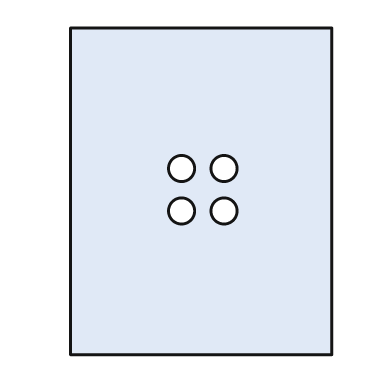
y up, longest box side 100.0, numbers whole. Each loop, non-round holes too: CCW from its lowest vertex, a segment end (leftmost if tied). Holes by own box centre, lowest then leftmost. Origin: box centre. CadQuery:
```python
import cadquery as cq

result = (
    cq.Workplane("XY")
    .moveTo(-40.0, -50.0)
    .lineTo(40.0, -50.0)
    .lineTo(40.0, 50.0)
    .lineTo(-40.0, 50.0)
    .close()
    .moveTo(-6.0, -6.0)
    .circle(4.0)
    .moveTo(7.0, -6.0)
    .circle(4.0)
    .moveTo(-6.0, 7.0)
    .circle(4.0)
    .moveTo(7.0, 7.0)
    .circle(4.0)
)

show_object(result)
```